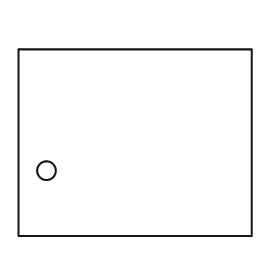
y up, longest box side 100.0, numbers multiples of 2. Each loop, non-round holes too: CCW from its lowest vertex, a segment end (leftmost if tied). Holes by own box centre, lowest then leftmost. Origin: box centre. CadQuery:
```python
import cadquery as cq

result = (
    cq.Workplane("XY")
    .moveTo(-50.0, -40.0)
    .lineTo(50.0, -40.0)
    .lineTo(50.0, 40.0)
    .lineTo(-50.0, 40.0)
    .close()
    .moveTo(-38.0, -12.0)
    .circle(4.0)
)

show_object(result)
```